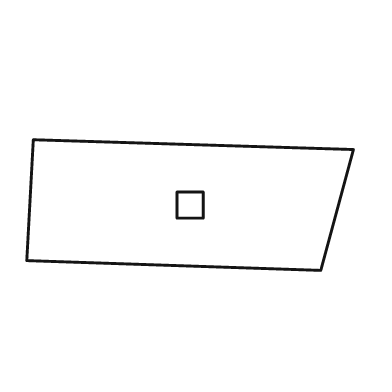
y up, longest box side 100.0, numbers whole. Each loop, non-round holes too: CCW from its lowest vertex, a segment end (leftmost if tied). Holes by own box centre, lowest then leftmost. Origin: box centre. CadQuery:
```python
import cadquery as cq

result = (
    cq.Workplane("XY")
    .moveTo(40.0, -20.0)
    .lineTo(50.0, 17.0)
    .lineTo(-48.0, 20.0)
    .lineTo(-50.0, -17.0)
    .close()
    .moveTo(-4.0, -4.0)
    .lineTo(4.0, -4.0)
    .lineTo(4.0, 4.0)
    .lineTo(-4.0, 4.0)
    .close()
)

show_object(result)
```